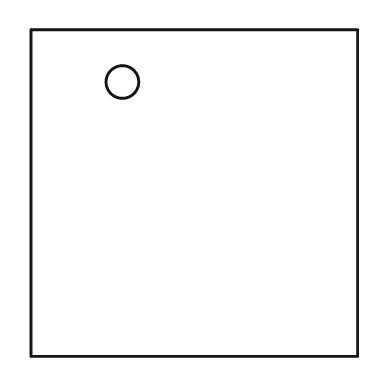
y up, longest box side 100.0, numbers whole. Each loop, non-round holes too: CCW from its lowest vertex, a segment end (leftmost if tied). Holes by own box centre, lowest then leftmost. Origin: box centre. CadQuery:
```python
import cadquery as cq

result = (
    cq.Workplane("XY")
    .moveTo(-50.0, -50.0)
    .lineTo(50.0, -50.0)
    .lineTo(50.0, 50.0)
    .lineTo(-50.0, 50.0)
    .close()
    .moveTo(-22.0, 34.0)
    .circle(5.0)
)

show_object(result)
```